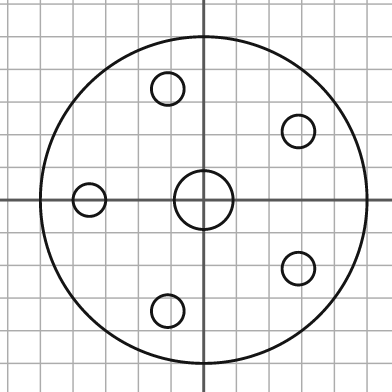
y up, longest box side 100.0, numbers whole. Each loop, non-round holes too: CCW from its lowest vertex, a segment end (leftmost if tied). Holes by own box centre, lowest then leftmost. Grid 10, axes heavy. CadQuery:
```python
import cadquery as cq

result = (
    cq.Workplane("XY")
    .moveTo(0.0, 0.0)
    .circle(50.0)
    .moveTo(-11.0, -34.0)
    .circle(5.0)
    .moveTo(29.0, -21.0)
    .circle(5.0)
    .moveTo(-35.0, 0.0)
    .circle(5.0)
    .moveTo(0.0, 0.0)
    .circle(9.0)
    .moveTo(29.0, 21.0)
    .circle(5.0)
    .moveTo(-11.0, 34.0)
    .circle(5.0)
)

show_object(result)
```